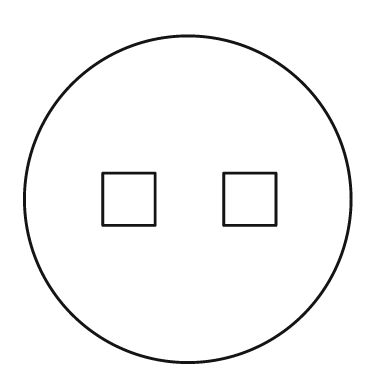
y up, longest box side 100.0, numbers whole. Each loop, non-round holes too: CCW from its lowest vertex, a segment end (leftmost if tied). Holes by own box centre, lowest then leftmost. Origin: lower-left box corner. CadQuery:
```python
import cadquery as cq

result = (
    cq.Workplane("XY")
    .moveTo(50.0, 50.0)
    .circle(50.0)
    .moveTo(24.0, 42.0)
    .lineTo(40.0, 42.0)
    .lineTo(40.0, 58.0)
    .lineTo(24.0, 58.0)
    .close()
    .moveTo(61.0, 42.0)
    .lineTo(77.0, 42.0)
    .lineTo(77.0, 58.0)
    .lineTo(61.0, 58.0)
    .close()
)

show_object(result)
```